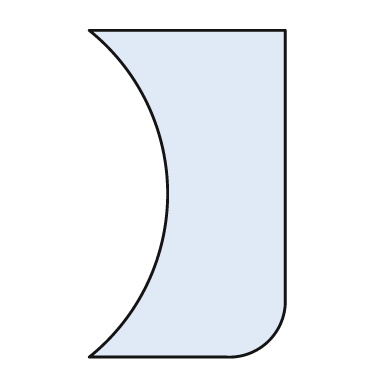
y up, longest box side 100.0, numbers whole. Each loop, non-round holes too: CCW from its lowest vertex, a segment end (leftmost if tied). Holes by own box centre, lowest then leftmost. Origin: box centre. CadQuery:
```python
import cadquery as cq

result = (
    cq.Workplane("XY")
    .moveTo(-30.0, -50.0)
    .lineTo(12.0, -50.0)
    .threePointArc((25.0, -45.0), (30.0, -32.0))
    .lineTo(30.0, 50.0)
    .lineTo(-30.0, 50.0)
    .threePointArc((-6.0, 0.0), (-30.0, -50.0))
    .close()
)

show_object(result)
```